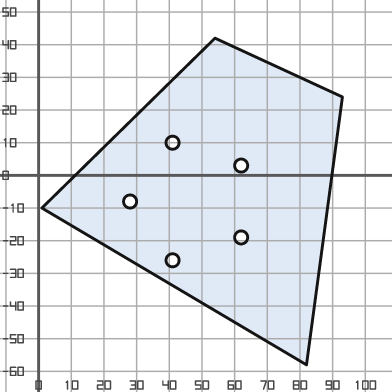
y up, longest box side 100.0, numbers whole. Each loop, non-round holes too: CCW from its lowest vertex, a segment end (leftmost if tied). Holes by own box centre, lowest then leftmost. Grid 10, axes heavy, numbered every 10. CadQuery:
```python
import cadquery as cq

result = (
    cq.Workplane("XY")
    .moveTo(82.0, -58.0)
    .lineTo(93.0, 24.0)
    .lineTo(54.0, 42.0)
    .lineTo(1.0, -10.0)
    .close()
    .moveTo(41.0, -26.0)
    .circle(2.0)
    .moveTo(62.0, -19.0)
    .circle(2.0)
    .moveTo(28.0, -8.0)
    .circle(2.0)
    .moveTo(62.0, 3.0)
    .circle(2.0)
    .moveTo(41.0, 10.0)
    .circle(2.0)
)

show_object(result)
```